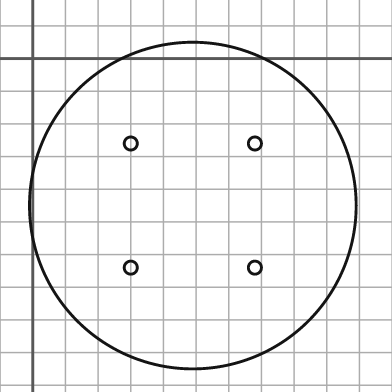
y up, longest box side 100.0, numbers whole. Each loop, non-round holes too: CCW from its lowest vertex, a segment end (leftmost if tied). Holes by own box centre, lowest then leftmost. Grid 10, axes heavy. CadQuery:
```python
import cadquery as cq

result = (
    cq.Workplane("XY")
    .moveTo(49.0, -45.0)
    .circle(50.0)
    .moveTo(30.0, -64.0)
    .circle(2.0)
    .moveTo(68.0, -64.0)
    .circle(2.0)
    .moveTo(30.0, -26.0)
    .circle(2.0)
    .moveTo(68.0, -26.0)
    .circle(2.0)
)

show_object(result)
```